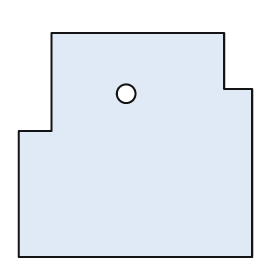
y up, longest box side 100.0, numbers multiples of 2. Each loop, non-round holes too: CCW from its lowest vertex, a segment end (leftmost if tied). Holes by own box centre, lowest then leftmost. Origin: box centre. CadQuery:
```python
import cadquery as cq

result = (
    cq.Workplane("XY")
    .moveTo(-50.0, -48.0)
    .lineTo(50.0, -48.0)
    .lineTo(50.0, 24.0)
    .lineTo(38.0, 24.0)
    .lineTo(38.0, 48.0)
    .lineTo(-36.0, 48.0)
    .lineTo(-36.0, 6.0)
    .lineTo(-50.0, 6.0)
    .close()
    .moveTo(-4.0, 22.0)
    .circle(4.0)
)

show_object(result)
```